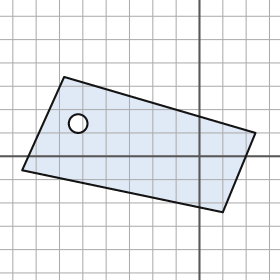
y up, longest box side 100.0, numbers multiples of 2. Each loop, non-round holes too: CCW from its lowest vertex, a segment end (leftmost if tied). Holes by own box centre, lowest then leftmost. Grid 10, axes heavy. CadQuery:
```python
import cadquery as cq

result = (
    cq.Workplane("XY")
    .moveTo(10.0, -24.0)
    .lineTo(24.0, 10.0)
    .lineTo(-58.0, 34.0)
    .lineTo(-76.0, -6.0)
    .close()
    .moveTo(-52.0, 14.0)
    .circle(4.0)
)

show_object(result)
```